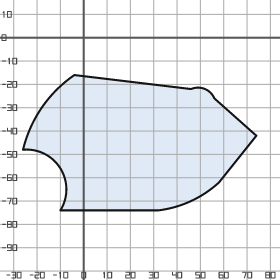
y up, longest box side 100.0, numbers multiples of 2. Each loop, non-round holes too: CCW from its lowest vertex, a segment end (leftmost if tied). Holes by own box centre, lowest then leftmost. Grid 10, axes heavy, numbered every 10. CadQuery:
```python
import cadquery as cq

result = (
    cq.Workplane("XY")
    .moveTo(-10.0, -74.0)
    .lineTo(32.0, -74.0)
    .threePointArc((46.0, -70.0), (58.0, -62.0))
    .lineTo(74.0, -42.0)
    .lineTo(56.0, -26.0)
    .threePointArc((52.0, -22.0), (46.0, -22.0))
    .lineTo(-4.0, -16.0)
    .threePointArc((-18.0, -30.0), (-26.0, -48.0))
    .threePointArc((-10.0, -56.0), (-10.0, -74.0))
    .close()
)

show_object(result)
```